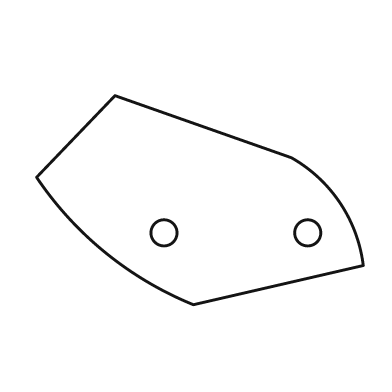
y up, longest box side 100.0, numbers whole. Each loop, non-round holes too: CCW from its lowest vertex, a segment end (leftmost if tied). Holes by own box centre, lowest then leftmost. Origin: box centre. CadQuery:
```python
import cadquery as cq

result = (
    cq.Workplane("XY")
    .moveTo(-2.0, -32.0)
    .lineTo(50.0, -20.0)
    .threePointArc((43.0, -1.0), (28.0, 13.0))
    .lineTo(-26.0, 32.0)
    .lineTo(-50.0, 7.0)
    .threePointArc((-29.0, -16.0), (-2.0, -32.0))
    .close()
    .moveTo(-11.0, -10.0)
    .circle(4.0)
    .moveTo(33.0, -10.0)
    .circle(4.0)
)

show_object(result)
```